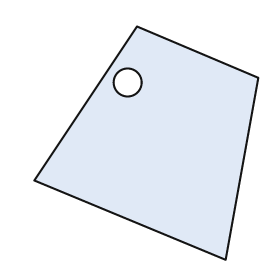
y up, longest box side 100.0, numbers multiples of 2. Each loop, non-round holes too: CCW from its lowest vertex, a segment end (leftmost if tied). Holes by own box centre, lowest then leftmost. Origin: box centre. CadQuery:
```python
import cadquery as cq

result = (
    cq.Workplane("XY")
    .moveTo(34.0, -50.0)
    .lineTo(48.0, 28.0)
    .lineTo(-4.0, 50.0)
    .lineTo(-48.0, -16.0)
    .close()
    .moveTo(-8.0, 26.0)
    .circle(6.0)
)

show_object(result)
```